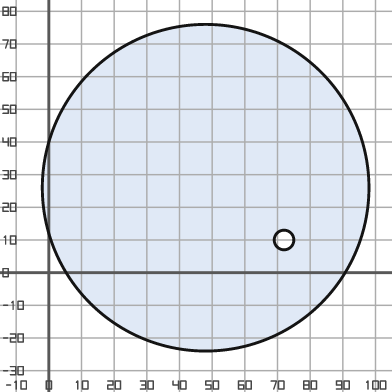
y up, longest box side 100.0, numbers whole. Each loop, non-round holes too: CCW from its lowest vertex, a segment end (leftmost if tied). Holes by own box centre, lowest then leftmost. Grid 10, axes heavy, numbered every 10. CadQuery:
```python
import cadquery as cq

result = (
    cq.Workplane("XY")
    .moveTo(48.0, 26.0)
    .circle(50.0)
    .moveTo(72.0, 10.0)
    .circle(3.0)
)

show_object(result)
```